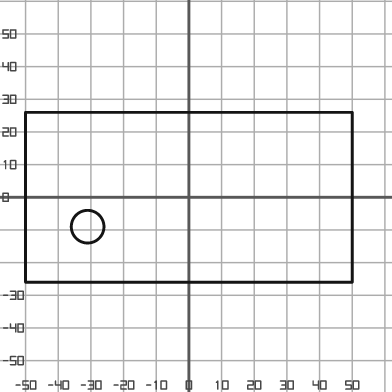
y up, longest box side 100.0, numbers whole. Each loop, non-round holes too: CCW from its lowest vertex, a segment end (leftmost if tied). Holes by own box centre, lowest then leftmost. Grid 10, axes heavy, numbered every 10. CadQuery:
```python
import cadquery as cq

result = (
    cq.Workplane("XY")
    .moveTo(-50.0, -26.0)
    .lineTo(50.0, -26.0)
    .lineTo(50.0, 26.0)
    .lineTo(-50.0, 26.0)
    .close()
    .moveTo(-31.0, -9.0)
    .circle(5.0)
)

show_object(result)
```